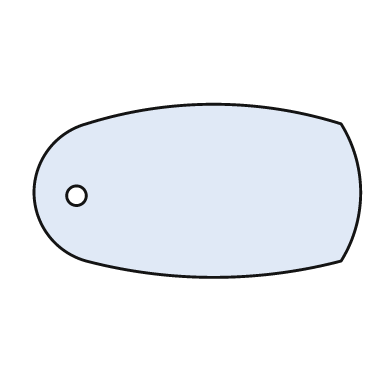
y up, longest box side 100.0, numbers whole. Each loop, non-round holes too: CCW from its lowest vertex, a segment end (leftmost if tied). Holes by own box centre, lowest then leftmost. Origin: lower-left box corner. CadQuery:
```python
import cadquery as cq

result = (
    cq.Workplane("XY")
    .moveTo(16.0, 5.0)
    .threePointArc((55.0, 0.0), (94.0, 5.0))
    .threePointArc((100.0, 26.0), (94.0, 47.0))
    .threePointArc((55.0, 53.0), (16.0, 47.0))
    .threePointArc((0.0, 26.0), (16.0, 5.0))
    .close()
    .moveTo(13.0, 25.0)
    .circle(3.0)
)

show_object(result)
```